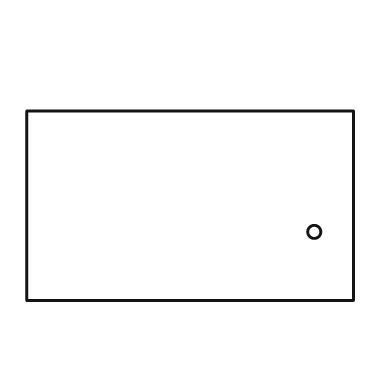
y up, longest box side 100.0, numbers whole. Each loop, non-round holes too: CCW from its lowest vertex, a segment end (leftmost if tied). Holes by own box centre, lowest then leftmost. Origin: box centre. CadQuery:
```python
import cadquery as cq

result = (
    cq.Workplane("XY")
    .moveTo(-50.0, -29.0)
    .lineTo(50.0, -29.0)
    .lineTo(50.0, 29.0)
    .lineTo(-50.0, 29.0)
    .close()
    .moveTo(38.0, -8.0)
    .circle(2.0)
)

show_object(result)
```